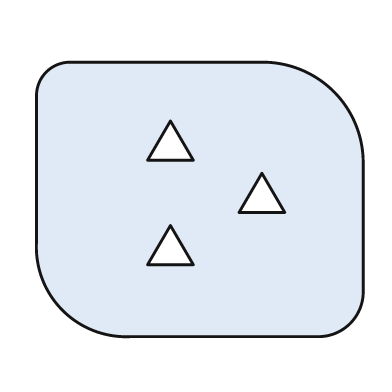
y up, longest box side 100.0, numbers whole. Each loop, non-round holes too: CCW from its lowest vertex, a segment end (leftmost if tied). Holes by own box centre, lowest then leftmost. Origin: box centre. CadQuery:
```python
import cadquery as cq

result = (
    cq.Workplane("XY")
    .moveTo(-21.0, -42.0)
    .lineTo(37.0, -42.0)
    .threePointArc((46.0, -38.0), (50.0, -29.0))
    .lineTo(50.0, 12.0)
    .threePointArc((41.0, 33.0), (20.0, 42.0))
    .lineTo(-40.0, 42.0)
    .threePointArc((-47.0, 39.0), (-50.0, 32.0))
    .lineTo(-50.0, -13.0)
    .threePointArc((-42.0, -34.0), (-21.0, -42.0))
    .close()
    .moveTo(-16.0, -20.0)
    .lineTo(-2.0, -20.0)
    .lineTo(-9.0, -8.0)
    .close()
    .moveTo(12.0, -4.0)
    .lineTo(26.0, -4.0)
    .lineTo(19.0, 8.0)
    .close()
    .moveTo(-16.0, 12.0)
    .lineTo(-2.0, 12.0)
    .lineTo(-9.0, 24.0)
    .close()
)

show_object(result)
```